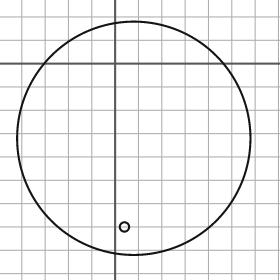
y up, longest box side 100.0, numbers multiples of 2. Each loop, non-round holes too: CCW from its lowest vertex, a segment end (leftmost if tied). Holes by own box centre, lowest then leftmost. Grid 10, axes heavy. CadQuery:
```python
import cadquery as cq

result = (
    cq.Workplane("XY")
    .moveTo(8.0, -32.0)
    .circle(50.0)
    .moveTo(4.0, -70.0)
    .circle(2.0)
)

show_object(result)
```